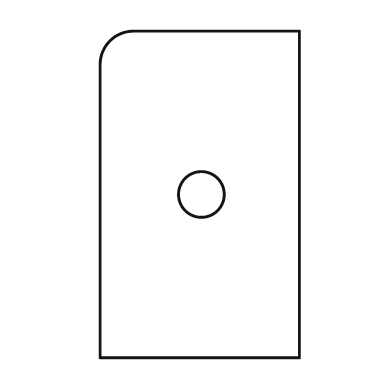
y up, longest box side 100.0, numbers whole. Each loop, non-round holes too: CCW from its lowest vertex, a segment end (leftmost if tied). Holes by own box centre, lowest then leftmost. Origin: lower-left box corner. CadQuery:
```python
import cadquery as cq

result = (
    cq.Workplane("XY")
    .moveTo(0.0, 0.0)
    .lineTo(61.0, 0.0)
    .lineTo(61.0, 100.0)
    .lineTo(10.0, 100.0)
    .threePointArc((3.0, 97.0), (0.0, 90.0))
    .close()
    .moveTo(31.0, 50.0)
    .circle(7.0)
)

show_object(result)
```